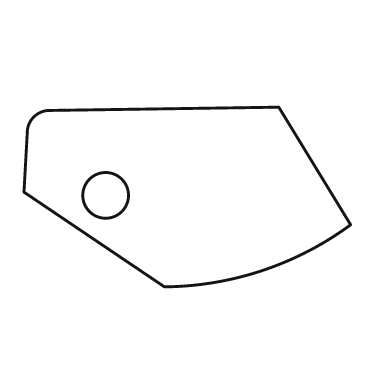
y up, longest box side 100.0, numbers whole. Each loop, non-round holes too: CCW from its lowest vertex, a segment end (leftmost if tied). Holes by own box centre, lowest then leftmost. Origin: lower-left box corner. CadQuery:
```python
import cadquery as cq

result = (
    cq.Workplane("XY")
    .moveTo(43.0, 0.0)
    .threePointArc((73.0, 5.0), (100.0, 19.0))
    .lineTo(78.0, 55.0)
    .lineTo(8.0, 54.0)
    .threePointArc((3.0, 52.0), (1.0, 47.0))
    .lineTo(0.0, 29.0)
    .close()
    .moveTo(25.0, 28.0)
    .circle(7.0)
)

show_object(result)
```